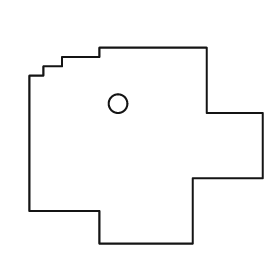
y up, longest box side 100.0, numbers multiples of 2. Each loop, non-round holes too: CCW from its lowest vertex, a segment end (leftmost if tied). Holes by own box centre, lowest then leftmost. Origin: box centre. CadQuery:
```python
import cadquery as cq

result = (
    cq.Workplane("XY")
    .moveTo(-20.0, -42.0)
    .lineTo(20.0, -42.0)
    .lineTo(20.0, -14.0)
    .lineTo(50.0, -14.0)
    .lineTo(50.0, 14.0)
    .lineTo(26.0, 14.0)
    .lineTo(26.0, 42.0)
    .lineTo(-20.0, 42.0)
    .lineTo(-20.0, 38.0)
    .lineTo(-36.0, 38.0)
    .lineTo(-36.0, 34.0)
    .lineTo(-44.0, 34.0)
    .lineTo(-44.0, 30.0)
    .lineTo(-50.0, 30.0)
    .lineTo(-50.0, -28.0)
    .lineTo(-20.0, -28.0)
    .close()
    .moveTo(-12.0, 18.0)
    .circle(4.0)
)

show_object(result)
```